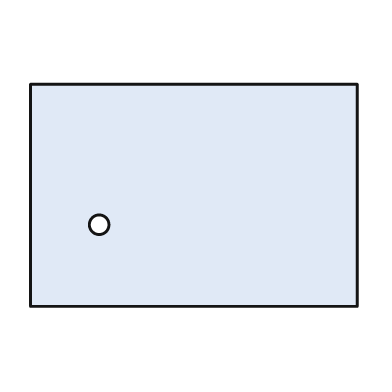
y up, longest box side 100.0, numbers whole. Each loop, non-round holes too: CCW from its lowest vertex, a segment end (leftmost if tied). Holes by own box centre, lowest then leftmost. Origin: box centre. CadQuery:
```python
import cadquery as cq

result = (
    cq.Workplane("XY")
    .moveTo(-50.0, -34.0)
    .lineTo(50.0, -34.0)
    .lineTo(50.0, 34.0)
    .lineTo(-50.0, 34.0)
    .close()
    .moveTo(-29.0, -9.0)
    .circle(3.0)
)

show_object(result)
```